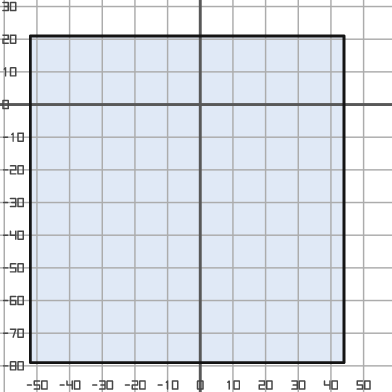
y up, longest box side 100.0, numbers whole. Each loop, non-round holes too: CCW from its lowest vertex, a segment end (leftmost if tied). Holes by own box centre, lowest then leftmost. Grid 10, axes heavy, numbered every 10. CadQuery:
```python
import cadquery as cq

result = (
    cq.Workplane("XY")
    .moveTo(-52.0, -79.0)
    .lineTo(44.0, -79.0)
    .lineTo(44.0, 21.0)
    .lineTo(-52.0, 21.0)
    .close()
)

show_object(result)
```